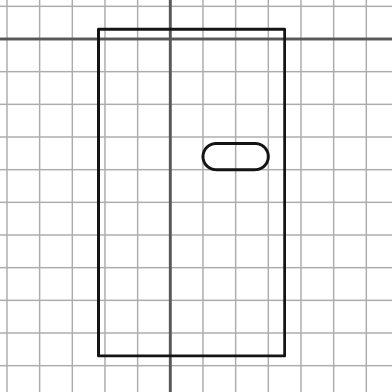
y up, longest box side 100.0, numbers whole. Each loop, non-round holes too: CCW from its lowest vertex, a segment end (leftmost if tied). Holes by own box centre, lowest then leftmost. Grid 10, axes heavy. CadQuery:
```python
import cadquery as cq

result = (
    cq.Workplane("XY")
    .moveTo(-22.0, -97.0)
    .lineTo(35.0, -97.0)
    .lineTo(35.0, 3.0)
    .lineTo(-22.0, 3.0)
    .close()
    .moveTo(14.0, -40.0)
    .lineTo(26.0, -40.0)
    .threePointArc((30.0, -36.0), (26.0, -32.0))
    .lineTo(14.0, -32.0)
    .threePointArc((10.0, -36.0), (14.0, -40.0))
    .close()
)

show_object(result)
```